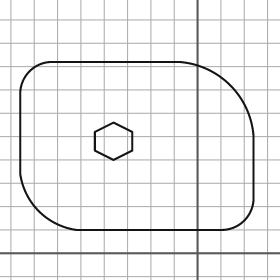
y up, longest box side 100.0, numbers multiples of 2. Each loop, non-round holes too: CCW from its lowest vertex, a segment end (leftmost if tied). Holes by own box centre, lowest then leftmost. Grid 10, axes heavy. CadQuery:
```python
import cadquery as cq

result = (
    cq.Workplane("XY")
    .moveTo(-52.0, 10.0)
    .lineTo(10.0, 10.0)
    .threePointArc((20.0, 14.0), (24.0, 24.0))
    .lineTo(24.0, 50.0)
    .threePointArc((14.0, 72.0), (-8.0, 82.0))
    .lineTo(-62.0, 82.0)
    .threePointArc((-72.0, 78.0), (-76.0, 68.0))
    .lineTo(-76.0, 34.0)
    .threePointArc((-68.0, 18.0), (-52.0, 10.0))
    .close()
    .moveTo(-36.0, 40.0)
    .lineTo(-28.0, 44.0)
    .lineTo(-28.0, 52.0)
    .lineTo(-36.0, 56.0)
    .lineTo(-44.0, 52.0)
    .lineTo(-44.0, 44.0)
    .close()
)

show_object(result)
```